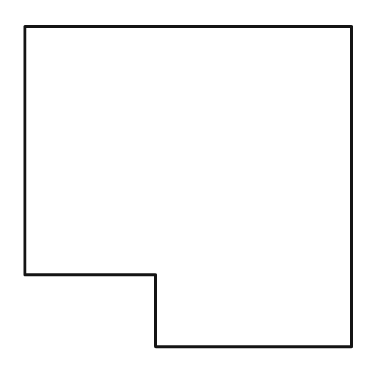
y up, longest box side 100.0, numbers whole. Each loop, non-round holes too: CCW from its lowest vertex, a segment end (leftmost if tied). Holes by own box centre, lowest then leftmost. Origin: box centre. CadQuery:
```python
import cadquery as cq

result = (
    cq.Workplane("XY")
    .moveTo(-10.0, -49.0)
    .lineTo(50.0, -49.0)
    .lineTo(50.0, 49.0)
    .lineTo(-50.0, 49.0)
    .lineTo(-50.0, -27.0)
    .lineTo(-10.0, -27.0)
    .close()
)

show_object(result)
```